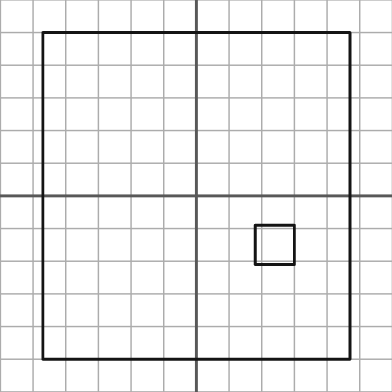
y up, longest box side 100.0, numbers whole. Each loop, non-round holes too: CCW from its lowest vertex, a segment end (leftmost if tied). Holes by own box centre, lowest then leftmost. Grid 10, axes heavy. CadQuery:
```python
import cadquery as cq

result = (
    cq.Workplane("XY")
    .moveTo(-47.0, -50.0)
    .lineTo(47.0, -50.0)
    .lineTo(47.0, 50.0)
    .lineTo(-47.0, 50.0)
    .close()
    .moveTo(18.0, -21.0)
    .lineTo(30.0, -21.0)
    .lineTo(30.0, -9.0)
    .lineTo(18.0, -9.0)
    .close()
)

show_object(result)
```